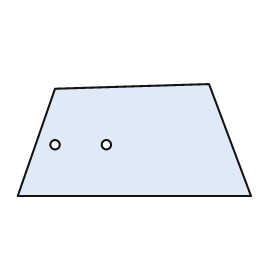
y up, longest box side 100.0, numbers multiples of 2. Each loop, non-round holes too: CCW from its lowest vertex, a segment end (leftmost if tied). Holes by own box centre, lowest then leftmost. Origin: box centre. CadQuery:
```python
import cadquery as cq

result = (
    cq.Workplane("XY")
    .moveTo(-50.0, -24.0)
    .lineTo(50.0, -24.0)
    .lineTo(32.0, 24.0)
    .lineTo(-34.0, 22.0)
    .close()
    .moveTo(-34.0, -2.0)
    .circle(2.0)
    .moveTo(-12.0, -2.0)
    .circle(2.0)
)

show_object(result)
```